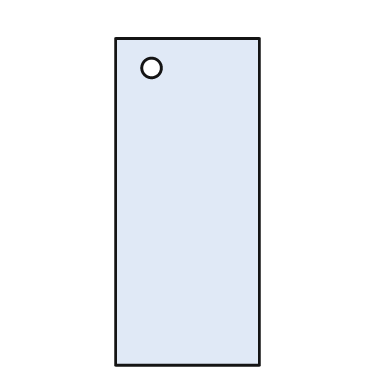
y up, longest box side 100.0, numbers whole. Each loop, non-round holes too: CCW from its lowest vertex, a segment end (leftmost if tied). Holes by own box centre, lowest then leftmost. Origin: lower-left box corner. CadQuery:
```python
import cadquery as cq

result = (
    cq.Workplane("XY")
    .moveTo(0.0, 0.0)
    .lineTo(44.0, 0.0)
    .lineTo(44.0, 100.0)
    .lineTo(0.0, 100.0)
    .close()
    .moveTo(11.0, 91.0)
    .circle(3.0)
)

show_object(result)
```